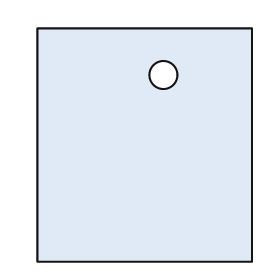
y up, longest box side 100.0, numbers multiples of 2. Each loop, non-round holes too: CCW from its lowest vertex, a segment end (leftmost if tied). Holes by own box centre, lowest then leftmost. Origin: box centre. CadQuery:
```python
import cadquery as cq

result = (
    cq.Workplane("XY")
    .moveTo(-46.0, -50.0)
    .lineTo(46.0, -50.0)
    .lineTo(46.0, 50.0)
    .lineTo(-46.0, 50.0)
    .close()
    .moveTo(8.0, 30.0)
    .circle(6.0)
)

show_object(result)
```